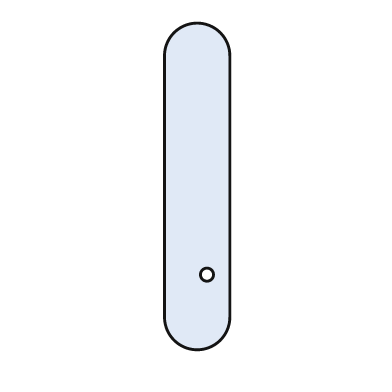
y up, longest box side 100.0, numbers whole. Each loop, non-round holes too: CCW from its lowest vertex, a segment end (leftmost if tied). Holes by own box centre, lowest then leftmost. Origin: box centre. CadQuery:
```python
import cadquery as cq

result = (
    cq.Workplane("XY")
    .moveTo(-10.0, -40.0)
    .threePointArc((0.0, -50.0), (10.0, -40.0))
    .lineTo(10.0, 40.0)
    .threePointArc((0.0, 50.0), (-10.0, 40.0))
    .close()
    .moveTo(3.0, -27.0)
    .circle(2.0)
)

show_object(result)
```